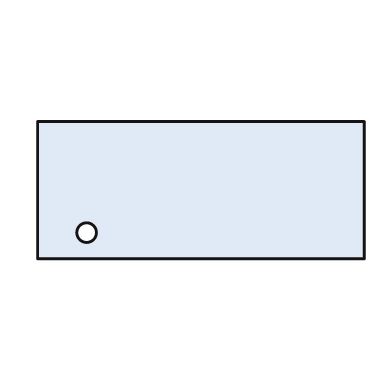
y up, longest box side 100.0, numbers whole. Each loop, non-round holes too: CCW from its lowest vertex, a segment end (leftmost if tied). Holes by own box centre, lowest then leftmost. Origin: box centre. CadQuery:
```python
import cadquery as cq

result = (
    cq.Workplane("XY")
    .moveTo(-50.0, -21.0)
    .lineTo(50.0, -21.0)
    .lineTo(50.0, 21.0)
    .lineTo(-50.0, 21.0)
    .close()
    .moveTo(-35.0, -13.0)
    .circle(3.0)
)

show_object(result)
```